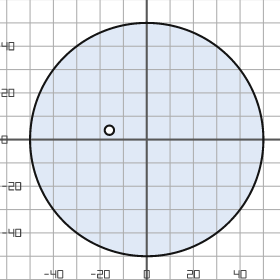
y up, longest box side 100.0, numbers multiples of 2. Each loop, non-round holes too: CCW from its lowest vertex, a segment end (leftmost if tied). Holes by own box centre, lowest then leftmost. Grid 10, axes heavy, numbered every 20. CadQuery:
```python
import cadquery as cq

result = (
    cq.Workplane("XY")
    .moveTo(0.0, 0.0)
    .circle(50.0)
    .moveTo(-16.0, 4.0)
    .circle(2.0)
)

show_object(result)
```